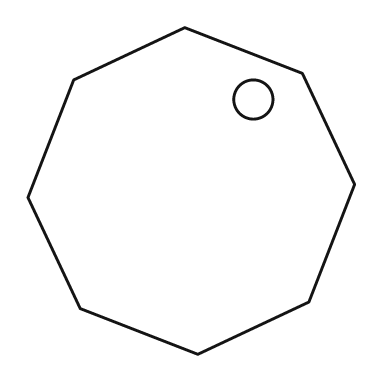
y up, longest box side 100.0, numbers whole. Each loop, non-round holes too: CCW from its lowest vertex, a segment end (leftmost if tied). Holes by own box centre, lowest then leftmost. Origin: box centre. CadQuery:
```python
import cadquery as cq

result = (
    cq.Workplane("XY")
    .moveTo(2.0, -50.0)
    .lineTo(36.0, -34.0)
    .lineTo(50.0, 2.0)
    .lineTo(34.0, 36.0)
    .lineTo(-2.0, 50.0)
    .lineTo(-36.0, 34.0)
    .lineTo(-50.0, -2.0)
    .lineTo(-34.0, -36.0)
    .close()
    .moveTo(19.0, 28.0)
    .circle(6.0)
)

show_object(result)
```